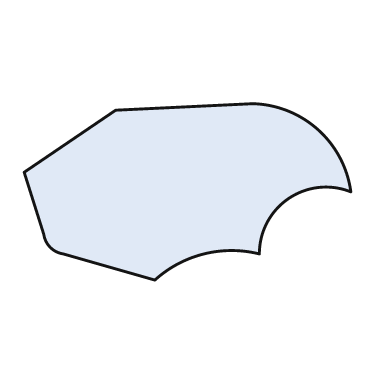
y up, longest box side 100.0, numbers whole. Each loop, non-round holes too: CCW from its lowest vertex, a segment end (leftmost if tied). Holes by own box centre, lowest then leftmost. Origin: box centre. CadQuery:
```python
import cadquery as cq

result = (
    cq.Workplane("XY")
    .moveTo(-10.0, -27.0)
    .threePointArc((5.0, -19.0), (22.0, -19.0))
    .threePointArc((31.0, -2.0), (50.0, 0.0))
    .threePointArc((40.0, 19.0), (20.0, 27.0))
    .lineTo(-22.0, 25.0)
    .lineTo(-50.0, 6.0)
    .lineTo(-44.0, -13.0)
    .threePointArc((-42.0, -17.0), (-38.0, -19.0))
    .close()
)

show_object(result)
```